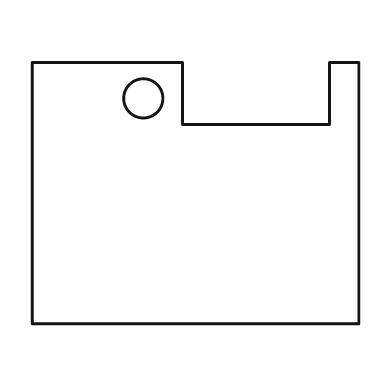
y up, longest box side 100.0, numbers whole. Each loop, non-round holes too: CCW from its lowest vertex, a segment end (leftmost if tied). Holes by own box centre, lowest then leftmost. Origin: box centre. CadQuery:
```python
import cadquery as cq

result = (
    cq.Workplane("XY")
    .moveTo(-50.0, -40.0)
    .lineTo(50.0, -40.0)
    .lineTo(50.0, 40.0)
    .lineTo(41.0, 40.0)
    .lineTo(41.0, 21.0)
    .lineTo(-4.0, 21.0)
    .lineTo(-4.0, 40.0)
    .lineTo(-50.0, 40.0)
    .close()
    .moveTo(-16.0, 29.0)
    .circle(6.0)
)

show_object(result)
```